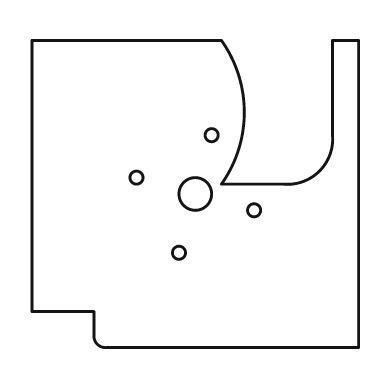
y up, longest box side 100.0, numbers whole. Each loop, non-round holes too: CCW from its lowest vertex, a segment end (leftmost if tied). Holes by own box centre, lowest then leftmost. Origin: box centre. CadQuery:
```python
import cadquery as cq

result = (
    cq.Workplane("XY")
    .moveTo(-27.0, -47.0)
    .lineTo(50.0, -47.0)
    .lineTo(50.0, 47.0)
    .lineTo(42.0, 47.0)
    .lineTo(42.0, 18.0)
    .threePointArc((38.0, 7.0), (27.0, 3.0))
    .lineTo(8.0, 3.0)
    .threePointArc((15.0, 25.0), (8.0, 47.0))
    .lineTo(-50.0, 47.0)
    .lineTo(-50.0, -36.0)
    .lineTo(-31.0, -36.0)
    .lineTo(-31.0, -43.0)
    .threePointArc((-30.0, -46.0), (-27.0, -47.0))
    .close()
    .moveTo(-5.0, -18.0)
    .circle(2.0)
    .moveTo(18.0, -5.0)
    .circle(2.0)
    .moveTo(0.0, 0.0)
    .circle(5.0)
    .moveTo(-18.0, 5.0)
    .circle(2.0)
    .moveTo(5.0, 18.0)
    .circle(2.0)
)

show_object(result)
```